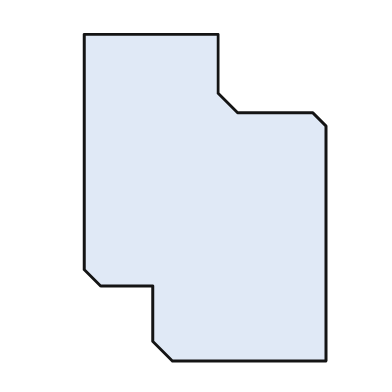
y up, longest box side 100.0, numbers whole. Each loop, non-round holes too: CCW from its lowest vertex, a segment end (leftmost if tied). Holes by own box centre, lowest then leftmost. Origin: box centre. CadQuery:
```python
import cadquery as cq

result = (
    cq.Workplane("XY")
    .moveTo(-10.0, -50.0)
    .lineTo(37.0, -50.0)
    .lineTo(37.0, 22.0)
    .lineTo(33.0, 26.0)
    .lineTo(10.0, 26.0)
    .lineTo(4.0, 32.0)
    .lineTo(4.0, 50.0)
    .lineTo(-37.0, 50.0)
    .lineTo(-37.0, -22.0)
    .lineTo(-32.0, -27.0)
    .lineTo(-16.0, -27.0)
    .lineTo(-16.0, -44.0)
    .close()
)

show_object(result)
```